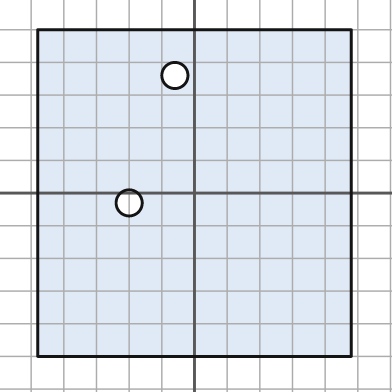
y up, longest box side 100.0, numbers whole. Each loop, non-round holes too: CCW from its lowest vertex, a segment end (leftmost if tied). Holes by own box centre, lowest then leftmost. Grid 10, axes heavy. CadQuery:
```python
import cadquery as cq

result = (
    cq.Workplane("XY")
    .moveTo(-48.0, -50.0)
    .lineTo(48.0, -50.0)
    .lineTo(48.0, 50.0)
    .lineTo(-48.0, 50.0)
    .close()
    .moveTo(-20.0, -3.0)
    .circle(4.0)
    .moveTo(-6.0, 36.0)
    .circle(4.0)
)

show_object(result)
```